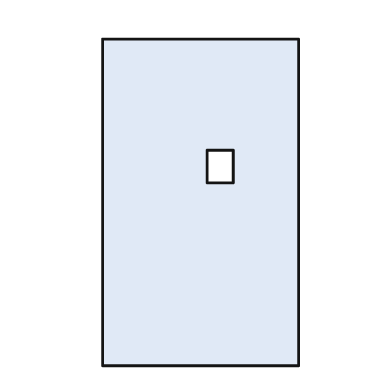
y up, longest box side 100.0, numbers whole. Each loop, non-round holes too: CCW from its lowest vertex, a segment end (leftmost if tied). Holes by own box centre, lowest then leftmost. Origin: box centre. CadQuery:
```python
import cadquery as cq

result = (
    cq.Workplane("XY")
    .moveTo(-30.0, -50.0)
    .lineTo(30.0, -50.0)
    .lineTo(30.0, 50.0)
    .lineTo(-30.0, 50.0)
    .close()
    .moveTo(2.0, 6.0)
    .lineTo(10.0, 6.0)
    .lineTo(10.0, 16.0)
    .lineTo(2.0, 16.0)
    .close()
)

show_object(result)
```